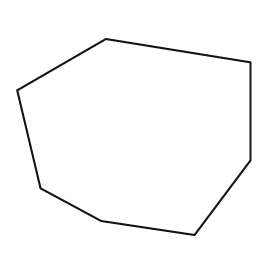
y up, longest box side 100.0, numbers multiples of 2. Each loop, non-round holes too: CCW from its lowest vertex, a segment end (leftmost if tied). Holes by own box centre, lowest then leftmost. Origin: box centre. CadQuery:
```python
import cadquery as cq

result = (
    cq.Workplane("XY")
    .moveTo(26.0, -42.0)
    .lineTo(50.0, -10.0)
    .lineTo(50.0, 32.0)
    .lineTo(-12.0, 42.0)
    .lineTo(-50.0, 20.0)
    .lineTo(-40.0, -22.0)
    .lineTo(-14.0, -36.0)
    .close()
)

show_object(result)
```